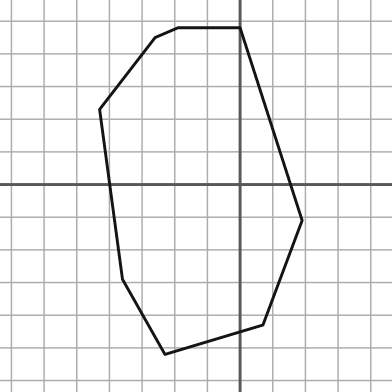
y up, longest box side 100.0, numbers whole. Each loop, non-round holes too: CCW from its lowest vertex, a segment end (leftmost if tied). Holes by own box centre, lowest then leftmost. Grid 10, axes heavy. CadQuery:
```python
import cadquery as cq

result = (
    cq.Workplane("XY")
    .moveTo(-23.0, -52.0)
    .lineTo(7.0, -43.0)
    .lineTo(19.0, -11.0)
    .lineTo(0.0, 48.0)
    .lineTo(-19.0, 48.0)
    .lineTo(-26.0, 45.0)
    .lineTo(-43.0, 23.0)
    .lineTo(-36.0, -29.0)
    .close()
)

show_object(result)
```